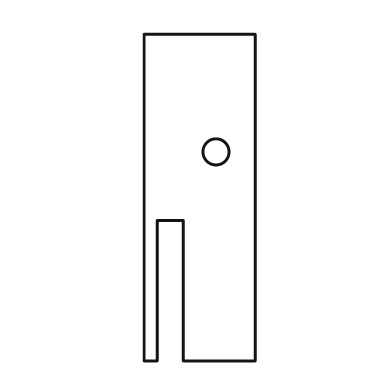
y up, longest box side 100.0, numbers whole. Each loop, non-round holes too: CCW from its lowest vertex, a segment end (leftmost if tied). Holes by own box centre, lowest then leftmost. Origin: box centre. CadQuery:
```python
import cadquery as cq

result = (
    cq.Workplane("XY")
    .moveTo(-17.0, -50.0)
    .lineTo(-13.0, -50.0)
    .lineTo(-13.0, -7.0)
    .lineTo(-5.0, -7.0)
    .lineTo(-5.0, -50.0)
    .lineTo(17.0, -50.0)
    .lineTo(17.0, 50.0)
    .lineTo(-17.0, 50.0)
    .close()
    .moveTo(5.0, 14.0)
    .circle(4.0)
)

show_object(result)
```